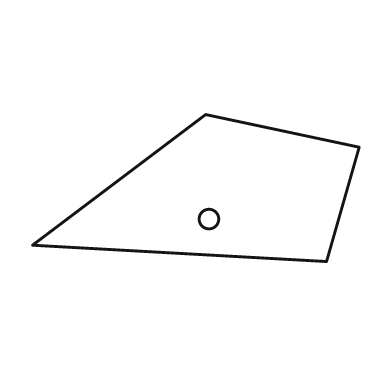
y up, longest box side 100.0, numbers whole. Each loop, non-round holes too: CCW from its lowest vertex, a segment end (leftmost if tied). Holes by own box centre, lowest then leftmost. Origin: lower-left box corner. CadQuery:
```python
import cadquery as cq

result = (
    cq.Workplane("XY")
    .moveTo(90.0, 0.0)
    .lineTo(100.0, 35.0)
    .lineTo(53.0, 45.0)
    .lineTo(0.0, 5.0)
    .close()
    .moveTo(54.0, 13.0)
    .circle(3.0)
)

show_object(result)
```